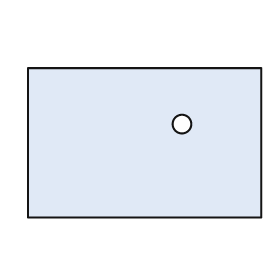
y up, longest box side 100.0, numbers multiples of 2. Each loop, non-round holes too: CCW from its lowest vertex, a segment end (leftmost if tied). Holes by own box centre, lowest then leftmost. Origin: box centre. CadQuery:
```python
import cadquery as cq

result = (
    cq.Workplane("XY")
    .moveTo(-50.0, -32.0)
    .lineTo(50.0, -32.0)
    .lineTo(50.0, 32.0)
    .lineTo(-50.0, 32.0)
    .close()
    .moveTo(16.0, 8.0)
    .circle(4.0)
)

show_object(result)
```